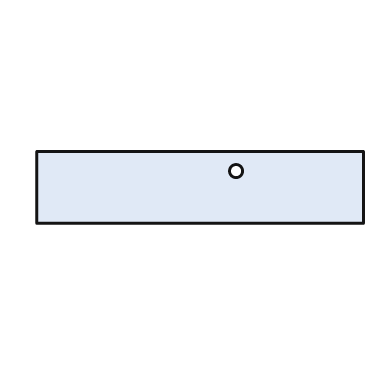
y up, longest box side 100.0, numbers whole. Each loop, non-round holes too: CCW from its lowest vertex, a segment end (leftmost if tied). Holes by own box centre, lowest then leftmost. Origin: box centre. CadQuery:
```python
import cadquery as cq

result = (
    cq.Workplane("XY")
    .moveTo(-50.0, -11.0)
    .lineTo(50.0, -11.0)
    .lineTo(50.0, 11.0)
    .lineTo(-50.0, 11.0)
    .close()
    .moveTo(11.0, 5.0)
    .circle(2.0)
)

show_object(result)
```